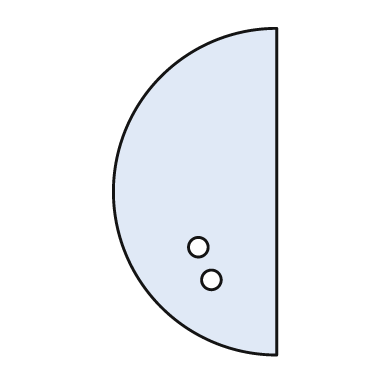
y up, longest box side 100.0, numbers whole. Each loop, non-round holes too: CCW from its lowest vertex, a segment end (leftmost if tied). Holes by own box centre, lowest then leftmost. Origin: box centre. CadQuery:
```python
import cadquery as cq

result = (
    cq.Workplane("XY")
    .moveTo(25.0, -50.0)
    .lineTo(25.0, 50.0)
    .threePointArc((-25.0, 0.0), (25.0, -50.0))
    .close()
    .moveTo(5.0, -27.0)
    .circle(3.0)
    .moveTo(1.0, -17.0)
    .circle(3.0)
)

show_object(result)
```